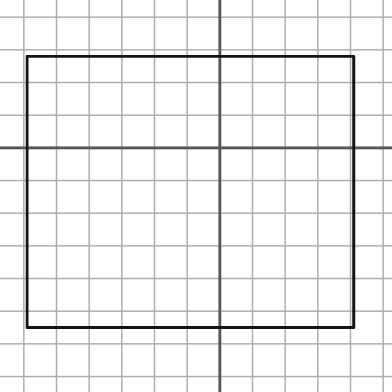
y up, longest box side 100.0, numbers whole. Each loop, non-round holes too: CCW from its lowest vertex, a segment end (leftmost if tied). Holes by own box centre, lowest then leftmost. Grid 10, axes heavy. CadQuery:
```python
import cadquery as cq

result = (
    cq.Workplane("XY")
    .moveTo(-59.0, -55.0)
    .lineTo(41.0, -55.0)
    .lineTo(41.0, 28.0)
    .lineTo(-59.0, 28.0)
    .close()
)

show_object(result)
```